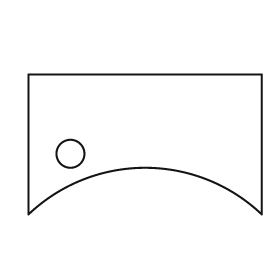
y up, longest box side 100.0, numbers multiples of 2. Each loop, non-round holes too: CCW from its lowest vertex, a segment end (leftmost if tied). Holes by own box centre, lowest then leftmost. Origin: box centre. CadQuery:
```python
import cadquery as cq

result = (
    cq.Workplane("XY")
    .moveTo(-50.0, -30.0)
    .threePointArc((0.0, -10.0), (50.0, -30.0))
    .lineTo(50.0, 30.0)
    .lineTo(-50.0, 30.0)
    .close()
    .moveTo(-32.0, -4.0)
    .circle(6.0)
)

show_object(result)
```